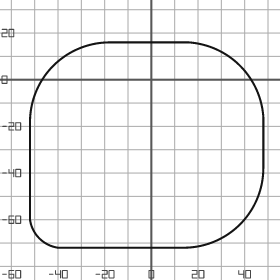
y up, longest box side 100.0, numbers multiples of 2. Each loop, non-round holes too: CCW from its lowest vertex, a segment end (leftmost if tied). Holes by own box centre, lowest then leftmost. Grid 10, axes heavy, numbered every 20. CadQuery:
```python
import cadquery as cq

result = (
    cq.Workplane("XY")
    .moveTo(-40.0, -72.0)
    .lineTo(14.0, -72.0)
    .threePointArc((38.0, -62.0), (48.0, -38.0))
    .lineTo(48.0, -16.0)
    .threePointArc((38.0, 6.0), (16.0, 16.0))
    .lineTo(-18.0, 16.0)
    .threePointArc((-42.0, 6.0), (-52.0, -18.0))
    .lineTo(-52.0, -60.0)
    .threePointArc((-48.0, -68.0), (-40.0, -72.0))
    .close()
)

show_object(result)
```